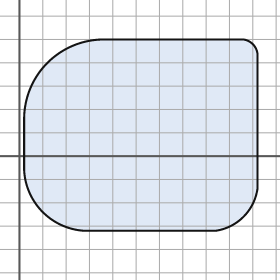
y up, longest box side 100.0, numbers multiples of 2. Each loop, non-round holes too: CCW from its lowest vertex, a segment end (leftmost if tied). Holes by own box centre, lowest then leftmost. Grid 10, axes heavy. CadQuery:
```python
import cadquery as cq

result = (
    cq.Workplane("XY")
    .moveTo(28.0, -32.0)
    .lineTo(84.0, -32.0)
    .threePointArc((96.0, -26.0), (102.0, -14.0))
    .lineTo(102.0, 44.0)
    .threePointArc((100.0, 48.0), (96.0, 50.0))
    .lineTo(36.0, 50.0)
    .threePointArc((12.0, 40.0), (2.0, 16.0))
    .lineTo(2.0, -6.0)
    .threePointArc((10.0, -24.0), (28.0, -32.0))
    .close()
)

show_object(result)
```